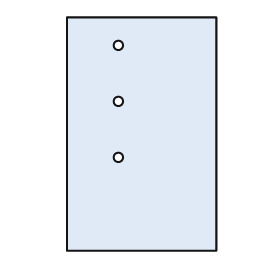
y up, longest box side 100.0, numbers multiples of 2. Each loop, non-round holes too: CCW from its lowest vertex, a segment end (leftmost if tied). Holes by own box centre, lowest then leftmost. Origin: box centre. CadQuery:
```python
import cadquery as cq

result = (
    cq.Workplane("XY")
    .moveTo(-32.0, -50.0)
    .lineTo(32.0, -50.0)
    .lineTo(32.0, 50.0)
    .lineTo(-32.0, 50.0)
    .close()
    .moveTo(-10.0, -10.0)
    .circle(2.0)
    .moveTo(-10.0, 14.0)
    .circle(2.0)
    .moveTo(-10.0, 38.0)
    .circle(2.0)
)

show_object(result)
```